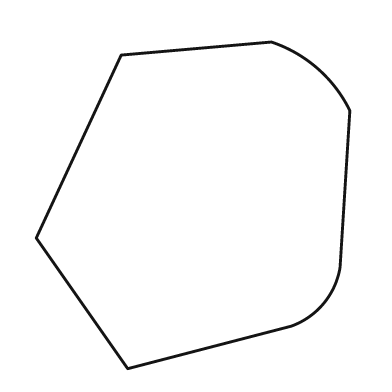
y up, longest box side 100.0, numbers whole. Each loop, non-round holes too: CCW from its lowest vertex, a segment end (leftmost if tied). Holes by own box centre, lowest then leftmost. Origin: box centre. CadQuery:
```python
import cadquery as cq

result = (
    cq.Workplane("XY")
    .moveTo(-20.0, -50.0)
    .lineTo(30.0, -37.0)
    .threePointArc((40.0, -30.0), (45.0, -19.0))
    .lineTo(48.0, 29.0)
    .threePointArc((38.0, 42.0), (24.0, 50.0))
    .lineTo(-22.0, 46.0)
    .lineTo(-48.0, -10.0)
    .close()
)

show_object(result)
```